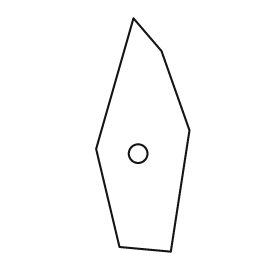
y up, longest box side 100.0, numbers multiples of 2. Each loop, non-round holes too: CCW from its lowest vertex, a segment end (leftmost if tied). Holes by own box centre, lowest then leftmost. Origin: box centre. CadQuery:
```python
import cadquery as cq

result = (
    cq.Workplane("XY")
    .moveTo(12.0, -50.0)
    .lineTo(20.0, 2.0)
    .lineTo(8.0, 36.0)
    .lineTo(-4.0, 50.0)
    .lineTo(-20.0, -6.0)
    .lineTo(-10.0, -48.0)
    .close()
    .moveTo(-2.0, -8.0)
    .circle(4.0)
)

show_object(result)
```